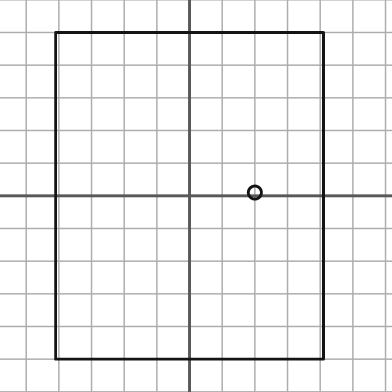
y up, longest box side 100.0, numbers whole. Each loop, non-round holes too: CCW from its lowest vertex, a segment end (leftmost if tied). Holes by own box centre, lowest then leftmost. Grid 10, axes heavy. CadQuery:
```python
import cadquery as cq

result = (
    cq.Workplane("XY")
    .moveTo(-41.0, -50.0)
    .lineTo(41.0, -50.0)
    .lineTo(41.0, 50.0)
    .lineTo(-41.0, 50.0)
    .close()
    .moveTo(20.0, 1.0)
    .circle(2.0)
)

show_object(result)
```